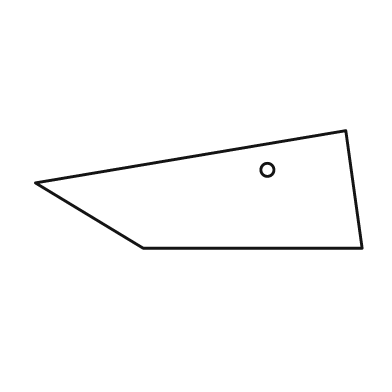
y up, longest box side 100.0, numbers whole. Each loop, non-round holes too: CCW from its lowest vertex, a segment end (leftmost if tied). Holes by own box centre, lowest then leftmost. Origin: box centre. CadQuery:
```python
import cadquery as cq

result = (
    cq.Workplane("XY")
    .moveTo(-17.0, -18.0)
    .lineTo(50.0, -18.0)
    .lineTo(45.0, 18.0)
    .lineTo(-50.0, 2.0)
    .close()
    .moveTo(21.0, 6.0)
    .circle(2.0)
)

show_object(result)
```